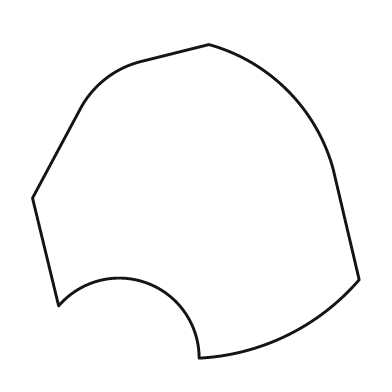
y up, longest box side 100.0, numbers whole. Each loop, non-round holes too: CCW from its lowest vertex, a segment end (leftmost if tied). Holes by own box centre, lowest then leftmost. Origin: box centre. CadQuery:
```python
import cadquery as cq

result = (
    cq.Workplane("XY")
    .moveTo(1.0, -48.0)
    .threePointArc((28.0, -41.0), (50.0, -24.0))
    .lineTo(42.0, 10.0)
    .threePointArc((28.0, 34.0), (4.0, 48.0))
    .lineTo(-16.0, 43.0)
    .threePointArc((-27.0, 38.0), (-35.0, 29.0))
    .lineTo(-50.0, 1.0)
    .lineTo(-42.0, -32.0)
    .threePointArc((-15.0, -25.0), (1.0, -48.0))
    .close()
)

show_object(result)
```